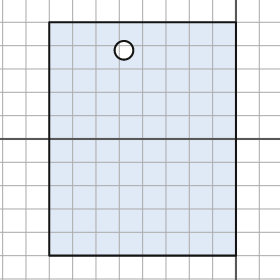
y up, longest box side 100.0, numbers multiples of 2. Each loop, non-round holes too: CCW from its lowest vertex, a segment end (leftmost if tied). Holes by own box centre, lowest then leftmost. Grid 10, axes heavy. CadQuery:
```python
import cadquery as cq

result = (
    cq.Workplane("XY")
    .moveTo(-80.0, -50.0)
    .lineTo(0.0, -50.0)
    .lineTo(0.0, 50.0)
    .lineTo(-80.0, 50.0)
    .close()
    .moveTo(-48.0, 38.0)
    .circle(4.0)
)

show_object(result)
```